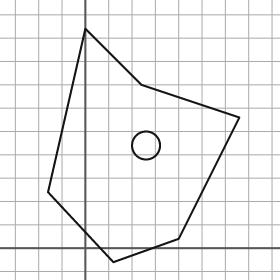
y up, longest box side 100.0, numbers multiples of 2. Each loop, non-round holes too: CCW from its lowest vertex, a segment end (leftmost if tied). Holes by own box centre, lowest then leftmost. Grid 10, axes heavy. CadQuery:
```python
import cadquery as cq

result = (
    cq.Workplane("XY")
    .moveTo(12.0, -6.0)
    .lineTo(40.0, 4.0)
    .lineTo(66.0, 56.0)
    .lineTo(24.0, 70.0)
    .lineTo(0.0, 94.0)
    .lineTo(-16.0, 24.0)
    .close()
    .moveTo(26.0, 44.0)
    .circle(6.0)
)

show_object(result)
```